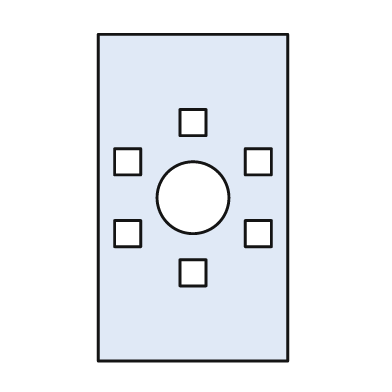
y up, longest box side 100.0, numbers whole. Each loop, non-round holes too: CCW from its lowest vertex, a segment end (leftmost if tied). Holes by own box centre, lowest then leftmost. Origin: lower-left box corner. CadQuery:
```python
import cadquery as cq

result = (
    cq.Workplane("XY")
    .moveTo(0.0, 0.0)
    .lineTo(58.0, 0.0)
    .lineTo(58.0, 100.0)
    .lineTo(0.0, 100.0)
    .close()
    .moveTo(25.0, 23.0)
    .lineTo(33.0, 23.0)
    .lineTo(33.0, 31.0)
    .lineTo(25.0, 31.0)
    .close()
    .moveTo(5.0, 35.0)
    .lineTo(13.0, 35.0)
    .lineTo(13.0, 43.0)
    .lineTo(5.0, 43.0)
    .close()
    .moveTo(45.0, 35.0)
    .lineTo(53.0, 35.0)
    .lineTo(53.0, 43.0)
    .lineTo(45.0, 43.0)
    .close()
    .moveTo(29.0, 50.0)
    .circle(11.0)
    .moveTo(5.0, 57.0)
    .lineTo(13.0, 57.0)
    .lineTo(13.0, 65.0)
    .lineTo(5.0, 65.0)
    .close()
    .moveTo(45.0, 57.0)
    .lineTo(53.0, 57.0)
    .lineTo(53.0, 65.0)
    .lineTo(45.0, 65.0)
    .close()
    .moveTo(25.0, 69.0)
    .lineTo(33.0, 69.0)
    .lineTo(33.0, 77.0)
    .lineTo(25.0, 77.0)
    .close()
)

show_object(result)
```